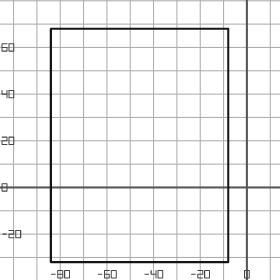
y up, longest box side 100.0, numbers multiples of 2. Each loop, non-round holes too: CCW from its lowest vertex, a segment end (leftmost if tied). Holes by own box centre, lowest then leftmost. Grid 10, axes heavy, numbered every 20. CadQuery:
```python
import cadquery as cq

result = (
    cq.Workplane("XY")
    .moveTo(-84.0, -32.0)
    .lineTo(-8.0, -32.0)
    .lineTo(-8.0, 68.0)
    .lineTo(-84.0, 68.0)
    .close()
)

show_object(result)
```